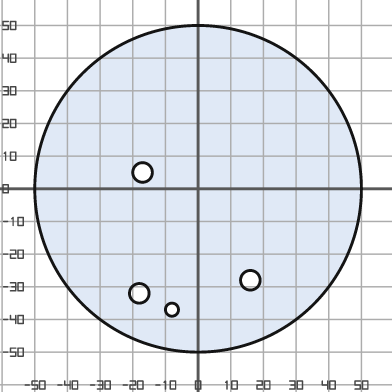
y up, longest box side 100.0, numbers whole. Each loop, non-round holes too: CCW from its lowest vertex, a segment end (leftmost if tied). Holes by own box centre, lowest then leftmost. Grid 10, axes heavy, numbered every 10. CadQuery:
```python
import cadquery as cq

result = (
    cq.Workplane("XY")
    .moveTo(0.0, 0.0)
    .circle(50.0)
    .moveTo(-8.0, -37.0)
    .circle(2.0)
    .moveTo(-18.0, -32.0)
    .circle(3.0)
    .moveTo(16.0, -28.0)
    .circle(3.0)
    .moveTo(-17.0, 5.0)
    .circle(3.0)
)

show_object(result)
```